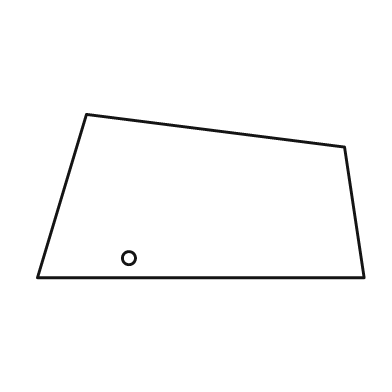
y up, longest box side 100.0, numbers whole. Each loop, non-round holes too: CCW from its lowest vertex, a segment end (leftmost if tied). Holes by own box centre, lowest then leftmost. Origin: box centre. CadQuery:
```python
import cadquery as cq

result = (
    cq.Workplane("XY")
    .moveTo(-50.0, -25.0)
    .lineTo(50.0, -25.0)
    .lineTo(44.0, 15.0)
    .lineTo(-35.0, 25.0)
    .close()
    .moveTo(-22.0, -19.0)
    .circle(2.0)
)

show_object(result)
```